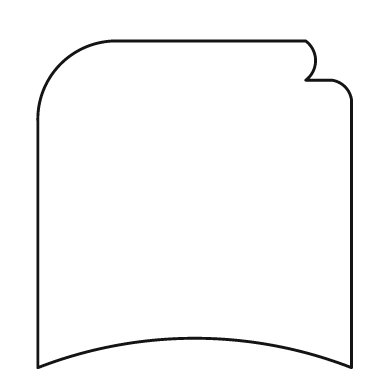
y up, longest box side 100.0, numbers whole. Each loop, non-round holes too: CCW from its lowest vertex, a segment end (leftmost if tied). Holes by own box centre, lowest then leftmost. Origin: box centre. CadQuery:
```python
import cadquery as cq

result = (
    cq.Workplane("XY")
    .moveTo(-48.0, -50.0)
    .threePointArc((0.0, -41.0), (48.0, -50.0))
    .lineTo(48.0, 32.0)
    .threePointArc((46.0, 36.0), (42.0, 38.0))
    .lineTo(34.0, 38.0)
    .threePointArc((37.0, 44.0), (34.0, 50.0))
    .lineTo(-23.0, 50.0)
    .threePointArc((-41.0, 43.0), (-48.0, 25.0))
    .close()
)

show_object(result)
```